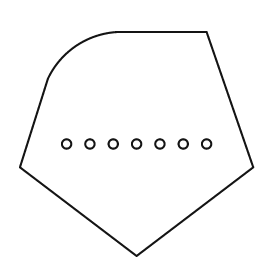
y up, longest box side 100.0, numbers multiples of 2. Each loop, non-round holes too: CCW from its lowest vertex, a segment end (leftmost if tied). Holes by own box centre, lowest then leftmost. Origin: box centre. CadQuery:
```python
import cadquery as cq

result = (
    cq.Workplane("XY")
    .moveTo(0.0, -48.0)
    .lineTo(50.0, -10.0)
    .lineTo(30.0, 48.0)
    .lineTo(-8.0, 48.0)
    .threePointArc((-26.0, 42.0), (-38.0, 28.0))
    .lineTo(-50.0, -10.0)
    .close()
    .moveTo(-30.0, 0.0)
    .circle(2.0)
    .moveTo(-20.0, 0.0)
    .circle(2.0)
    .moveTo(-10.0, 0.0)
    .circle(2.0)
    .moveTo(0.0, 0.0)
    .circle(2.0)
    .moveTo(10.0, 0.0)
    .circle(2.0)
    .moveTo(20.0, 0.0)
    .circle(2.0)
    .moveTo(30.0, 0.0)
    .circle(2.0)
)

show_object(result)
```